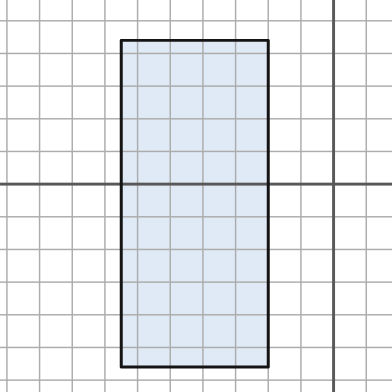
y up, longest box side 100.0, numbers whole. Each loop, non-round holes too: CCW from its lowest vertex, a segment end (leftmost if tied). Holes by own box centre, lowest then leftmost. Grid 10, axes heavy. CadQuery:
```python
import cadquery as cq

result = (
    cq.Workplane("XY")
    .moveTo(-65.0, -56.0)
    .lineTo(-20.0, -56.0)
    .lineTo(-20.0, 44.0)
    .lineTo(-65.0, 44.0)
    .close()
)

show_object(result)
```